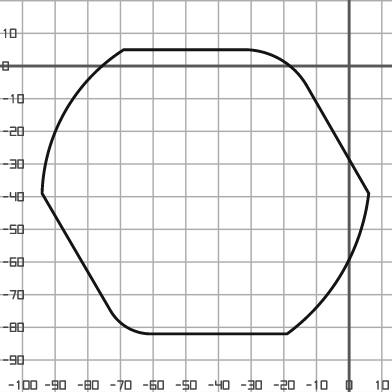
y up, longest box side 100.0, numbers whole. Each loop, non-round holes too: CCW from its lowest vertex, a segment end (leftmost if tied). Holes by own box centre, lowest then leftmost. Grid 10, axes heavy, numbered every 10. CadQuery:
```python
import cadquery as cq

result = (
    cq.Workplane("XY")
    .moveTo(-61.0, -82.0)
    .lineTo(-19.0, -82.0)
    .threePointArc((-2.0, -63.0), (6.0, -39.0))
    .lineTo(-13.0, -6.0)
    .threePointArc((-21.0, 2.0), (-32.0, 5.0))
    .lineTo(-69.0, 5.0)
    .threePointArc((-87.0, -14.0), (-94.0, -39.0))
    .lineTo(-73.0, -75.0)
    .threePointArc((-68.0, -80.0), (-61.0, -82.0))
    .close()
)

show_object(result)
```